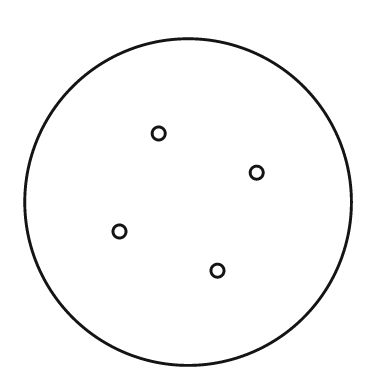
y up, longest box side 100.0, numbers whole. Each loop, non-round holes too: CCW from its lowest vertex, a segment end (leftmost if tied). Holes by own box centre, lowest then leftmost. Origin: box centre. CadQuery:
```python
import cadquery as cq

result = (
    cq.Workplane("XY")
    .moveTo(0.0, 0.0)
    .circle(50.0)
    .moveTo(9.0, -21.0)
    .circle(2.0)
    .moveTo(-21.0, -9.0)
    .circle(2.0)
    .moveTo(21.0, 9.0)
    .circle(2.0)
    .moveTo(-9.0, 21.0)
    .circle(2.0)
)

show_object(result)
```